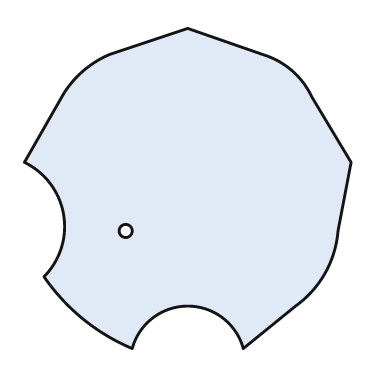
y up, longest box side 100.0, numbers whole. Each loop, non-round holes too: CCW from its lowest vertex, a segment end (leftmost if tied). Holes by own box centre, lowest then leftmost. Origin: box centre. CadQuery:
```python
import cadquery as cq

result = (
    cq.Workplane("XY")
    .moveTo(-17.0, -49.0)
    .threePointArc((0.0, -36.0), (17.0, -49.0))
    .lineTo(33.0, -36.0)
    .threePointArc((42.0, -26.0), (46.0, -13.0))
    .lineTo(50.0, 8.0)
    .lineTo(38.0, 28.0)
    .threePointArc((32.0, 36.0), (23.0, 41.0))
    .lineTo(0.0, 49.0)
    .lineTo(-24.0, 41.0)
    .threePointArc((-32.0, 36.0), (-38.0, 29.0))
    .lineTo(-50.0, 8.0)
    .threePointArc((-38.0, -8.0), (-44.0, -27.0))
    .threePointArc((-32.0, -40.0), (-17.0, -49.0))
    .close()
    .moveTo(-19.0, -13.0)
    .circle(2.0)
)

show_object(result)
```